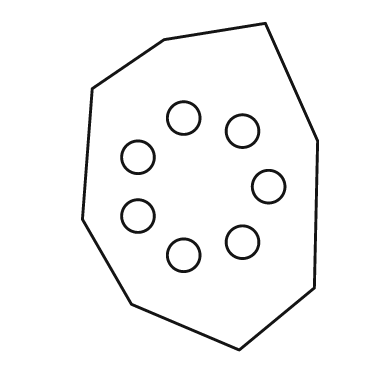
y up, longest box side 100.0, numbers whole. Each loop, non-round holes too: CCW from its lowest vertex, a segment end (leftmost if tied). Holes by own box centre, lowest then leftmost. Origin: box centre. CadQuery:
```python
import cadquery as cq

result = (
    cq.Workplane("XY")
    .moveTo(12.0, -50.0)
    .lineTo(35.0, -31.0)
    .lineTo(36.0, 14.0)
    .lineTo(20.0, 50.0)
    .lineTo(-11.0, 45.0)
    .lineTo(-33.0, 30.0)
    .lineTo(-36.0, -10.0)
    .lineTo(-21.0, -36.0)
    .close()
    .moveTo(-5.0, -21.0)
    .circle(5.0)
    .moveTo(13.0, -17.0)
    .circle(5.0)
    .moveTo(-19.0, -9.0)
    .circle(5.0)
    .moveTo(21.0, 0.0)
    .circle(5.0)
    .moveTo(-19.0, 9.0)
    .circle(5.0)
    .moveTo(13.0, 17.0)
    .circle(5.0)
    .moveTo(-5.0, 21.0)
    .circle(5.0)
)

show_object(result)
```